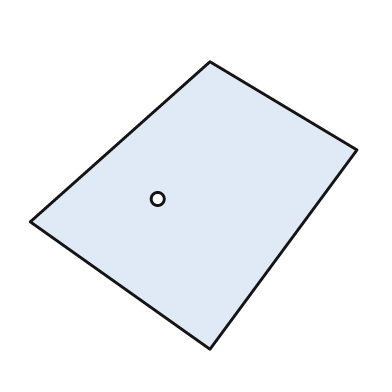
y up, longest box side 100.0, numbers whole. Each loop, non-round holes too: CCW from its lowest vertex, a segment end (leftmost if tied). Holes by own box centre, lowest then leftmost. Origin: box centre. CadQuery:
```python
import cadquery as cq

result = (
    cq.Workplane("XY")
    .moveTo(5.0, -44.0)
    .lineTo(50.0, 17.0)
    .lineTo(5.0, 44.0)
    .lineTo(-50.0, -5.0)
    .close()
    .moveTo(-11.0, 2.0)
    .circle(2.0)
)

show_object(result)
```